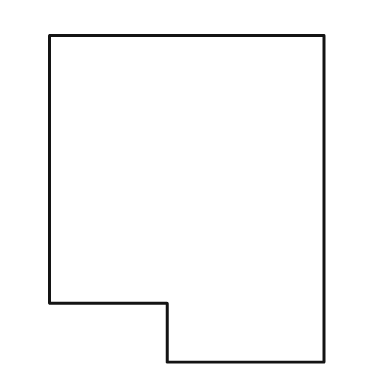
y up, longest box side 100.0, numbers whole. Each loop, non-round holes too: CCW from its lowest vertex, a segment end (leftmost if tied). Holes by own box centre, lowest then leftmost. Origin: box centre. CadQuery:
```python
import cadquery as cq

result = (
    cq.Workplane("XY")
    .moveTo(-6.0, -50.0)
    .lineTo(42.0, -50.0)
    .lineTo(42.0, 50.0)
    .lineTo(-42.0, 50.0)
    .lineTo(-42.0, -32.0)
    .lineTo(-6.0, -32.0)
    .close()
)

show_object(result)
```